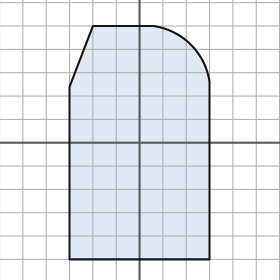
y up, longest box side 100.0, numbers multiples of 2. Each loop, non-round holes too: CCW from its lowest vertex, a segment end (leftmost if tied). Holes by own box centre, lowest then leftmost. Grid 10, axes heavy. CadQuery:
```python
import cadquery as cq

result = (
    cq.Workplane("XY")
    .moveTo(-30.0, -50.0)
    .lineTo(30.0, -50.0)
    .lineTo(30.0, 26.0)
    .threePointArc((22.0, 42.0), (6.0, 50.0))
    .lineTo(-20.0, 50.0)
    .lineTo(-30.0, 24.0)
    .close()
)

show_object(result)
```